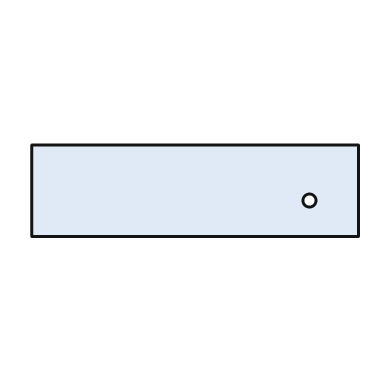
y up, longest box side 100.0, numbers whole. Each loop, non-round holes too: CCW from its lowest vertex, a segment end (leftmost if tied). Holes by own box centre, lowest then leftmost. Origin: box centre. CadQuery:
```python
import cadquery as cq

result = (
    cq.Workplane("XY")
    .moveTo(-50.0, -14.0)
    .lineTo(50.0, -14.0)
    .lineTo(50.0, 14.0)
    .lineTo(-50.0, 14.0)
    .close()
    .moveTo(35.0, -3.0)
    .circle(2.0)
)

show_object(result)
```